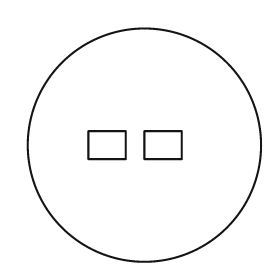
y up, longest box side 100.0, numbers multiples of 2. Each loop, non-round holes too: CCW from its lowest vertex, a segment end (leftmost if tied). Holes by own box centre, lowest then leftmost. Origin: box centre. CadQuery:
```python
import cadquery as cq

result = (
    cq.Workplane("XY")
    .moveTo(0.0, 0.0)
    .circle(50.0)
    .moveTo(-24.0, -6.0)
    .lineTo(-8.0, -6.0)
    .lineTo(-8.0, 6.0)
    .lineTo(-24.0, 6.0)
    .close()
    .moveTo(0.0, -6.0)
    .lineTo(16.0, -6.0)
    .lineTo(16.0, 6.0)
    .lineTo(0.0, 6.0)
    .close()
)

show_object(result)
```